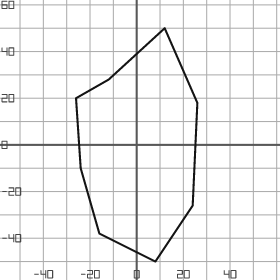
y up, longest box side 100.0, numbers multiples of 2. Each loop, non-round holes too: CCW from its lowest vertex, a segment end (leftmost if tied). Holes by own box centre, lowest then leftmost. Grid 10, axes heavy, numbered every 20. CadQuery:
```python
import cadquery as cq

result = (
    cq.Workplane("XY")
    .moveTo(8.0, -50.0)
    .lineTo(24.0, -26.0)
    .lineTo(26.0, 18.0)
    .lineTo(12.0, 50.0)
    .lineTo(-12.0, 28.0)
    .lineTo(-26.0, 20.0)
    .lineTo(-24.0, -10.0)
    .lineTo(-16.0, -38.0)
    .close()
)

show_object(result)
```